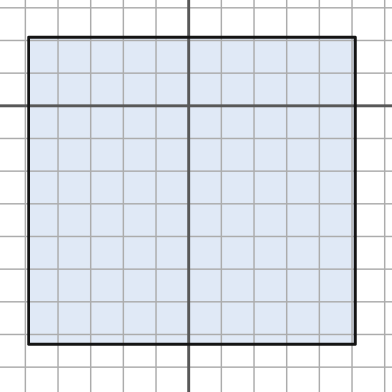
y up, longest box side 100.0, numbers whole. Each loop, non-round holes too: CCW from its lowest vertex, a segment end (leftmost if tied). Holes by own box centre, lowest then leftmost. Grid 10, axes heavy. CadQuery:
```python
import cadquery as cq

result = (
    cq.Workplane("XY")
    .moveTo(-49.0, -73.0)
    .lineTo(51.0, -73.0)
    .lineTo(51.0, 21.0)
    .lineTo(-49.0, 21.0)
    .close()
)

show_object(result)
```